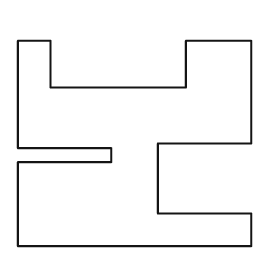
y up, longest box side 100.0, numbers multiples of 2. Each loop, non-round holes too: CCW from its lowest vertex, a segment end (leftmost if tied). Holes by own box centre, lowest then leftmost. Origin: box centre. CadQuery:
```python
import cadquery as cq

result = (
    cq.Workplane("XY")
    .moveTo(-50.0, -44.0)
    .lineTo(50.0, -44.0)
    .lineTo(50.0, -30.0)
    .lineTo(10.0, -30.0)
    .lineTo(10.0, 0.0)
    .lineTo(50.0, 0.0)
    .lineTo(50.0, 44.0)
    .lineTo(22.0, 44.0)
    .lineTo(22.0, 24.0)
    .lineTo(-36.0, 24.0)
    .lineTo(-36.0, 44.0)
    .lineTo(-50.0, 44.0)
    .lineTo(-50.0, -2.0)
    .lineTo(-10.0, -2.0)
    .lineTo(-10.0, -8.0)
    .lineTo(-50.0, -8.0)
    .close()
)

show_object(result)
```